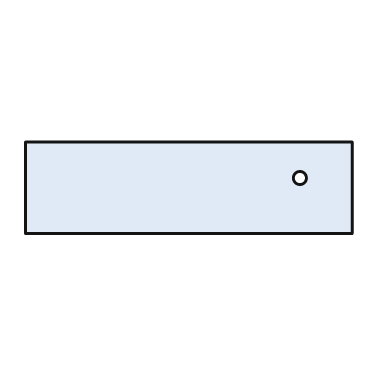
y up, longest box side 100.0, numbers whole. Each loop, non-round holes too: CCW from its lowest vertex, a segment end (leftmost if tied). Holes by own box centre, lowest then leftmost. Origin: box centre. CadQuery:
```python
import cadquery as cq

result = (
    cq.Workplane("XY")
    .moveTo(-50.0, -14.0)
    .lineTo(50.0, -14.0)
    .lineTo(50.0, 14.0)
    .lineTo(-50.0, 14.0)
    .close()
    .moveTo(34.0, 3.0)
    .circle(2.0)
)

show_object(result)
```